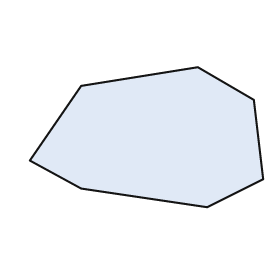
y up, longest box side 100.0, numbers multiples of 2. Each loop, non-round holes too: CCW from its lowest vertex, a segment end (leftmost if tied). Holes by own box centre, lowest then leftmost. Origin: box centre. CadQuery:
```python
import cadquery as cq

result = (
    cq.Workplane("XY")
    .moveTo(26.0, -30.0)
    .lineTo(50.0, -18.0)
    .lineTo(46.0, 16.0)
    .lineTo(22.0, 30.0)
    .lineTo(-28.0, 22.0)
    .lineTo(-50.0, -10.0)
    .lineTo(-28.0, -22.0)
    .close()
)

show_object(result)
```